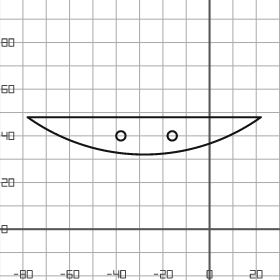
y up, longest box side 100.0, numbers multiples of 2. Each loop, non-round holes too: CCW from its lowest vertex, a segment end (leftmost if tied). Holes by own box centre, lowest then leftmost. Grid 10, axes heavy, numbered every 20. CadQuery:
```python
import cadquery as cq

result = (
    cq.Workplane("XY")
    .moveTo(-78.0, 48.0)
    .threePointArc((-28.0, 32.0), (22.0, 48.0))
    .close()
    .moveTo(-38.0, 40.0)
    .circle(2.0)
    .moveTo(-16.0, 40.0)
    .circle(2.0)
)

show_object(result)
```